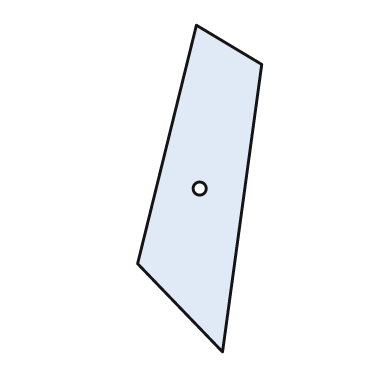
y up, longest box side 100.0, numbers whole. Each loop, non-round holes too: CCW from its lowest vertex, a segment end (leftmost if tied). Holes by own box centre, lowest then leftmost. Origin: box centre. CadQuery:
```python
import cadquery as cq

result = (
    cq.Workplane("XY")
    .moveTo(7.0, -50.0)
    .lineTo(19.0, 38.0)
    .lineTo(-1.0, 50.0)
    .lineTo(-19.0, -23.0)
    .close()
    .moveTo(0.0, 0.0)
    .circle(2.0)
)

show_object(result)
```